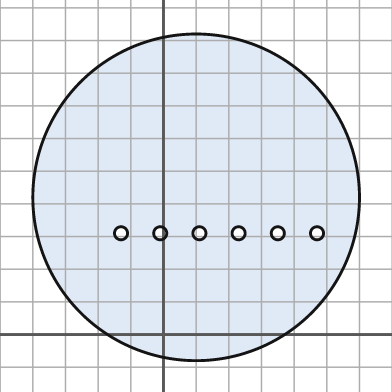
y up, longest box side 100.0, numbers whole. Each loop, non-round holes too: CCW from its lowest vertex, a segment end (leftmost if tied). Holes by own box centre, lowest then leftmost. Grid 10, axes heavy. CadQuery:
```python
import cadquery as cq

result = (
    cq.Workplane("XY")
    .moveTo(10.0, 42.0)
    .circle(50.0)
    .moveTo(-13.0, 31.0)
    .circle(2.0)
    .moveTo(-1.0, 31.0)
    .circle(2.0)
    .moveTo(11.0, 31.0)
    .circle(2.0)
    .moveTo(23.0, 31.0)
    .circle(2.0)
    .moveTo(35.0, 31.0)
    .circle(2.0)
    .moveTo(47.0, 31.0)
    .circle(2.0)
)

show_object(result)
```